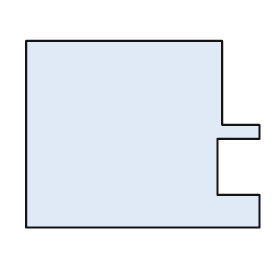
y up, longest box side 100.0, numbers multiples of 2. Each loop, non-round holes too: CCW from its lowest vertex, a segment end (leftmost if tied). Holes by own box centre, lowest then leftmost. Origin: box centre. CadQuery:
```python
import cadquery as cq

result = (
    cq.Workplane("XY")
    .moveTo(-50.0, -40.0)
    .lineTo(50.0, -40.0)
    .lineTo(50.0, -26.0)
    .lineTo(32.0, -26.0)
    .lineTo(32.0, -2.0)
    .lineTo(50.0, -2.0)
    .lineTo(50.0, 4.0)
    .lineTo(34.0, 4.0)
    .lineTo(34.0, 40.0)
    .lineTo(-50.0, 40.0)
    .close()
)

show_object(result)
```